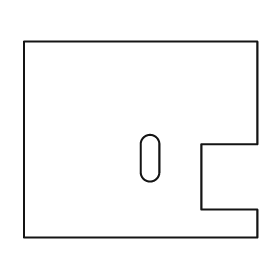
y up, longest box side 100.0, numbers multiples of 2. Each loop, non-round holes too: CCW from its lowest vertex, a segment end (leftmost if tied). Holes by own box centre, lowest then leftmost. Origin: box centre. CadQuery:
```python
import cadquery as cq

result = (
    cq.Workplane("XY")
    .moveTo(-50.0, -42.0)
    .lineTo(50.0, -42.0)
    .lineTo(50.0, -30.0)
    .lineTo(26.0, -30.0)
    .lineTo(26.0, -2.0)
    .lineTo(50.0, -2.0)
    .lineTo(50.0, 42.0)
    .lineTo(-50.0, 42.0)
    .close()
    .moveTo(0.0, -14.0)
    .threePointArc((4.0, -18.0), (8.0, -14.0))
    .lineTo(8.0, -2.0)
    .threePointArc((4.0, 2.0), (0.0, -2.0))
    .close()
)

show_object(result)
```